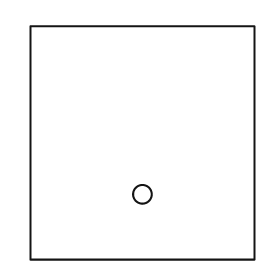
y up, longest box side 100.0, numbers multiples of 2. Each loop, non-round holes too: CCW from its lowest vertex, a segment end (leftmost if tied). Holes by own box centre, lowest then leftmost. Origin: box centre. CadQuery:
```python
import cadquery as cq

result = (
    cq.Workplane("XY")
    .moveTo(-48.0, -50.0)
    .lineTo(48.0, -50.0)
    .lineTo(48.0, 50.0)
    .lineTo(-48.0, 50.0)
    .close()
    .moveTo(0.0, -22.0)
    .circle(4.0)
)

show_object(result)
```